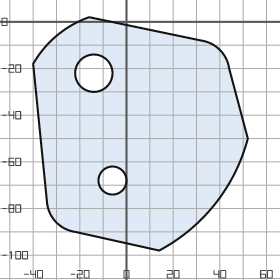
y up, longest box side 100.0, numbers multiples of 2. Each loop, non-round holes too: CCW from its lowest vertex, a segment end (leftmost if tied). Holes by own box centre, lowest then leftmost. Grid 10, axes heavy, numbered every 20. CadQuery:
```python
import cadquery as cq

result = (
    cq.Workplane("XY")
    .moveTo(14.0, -98.0)
    .threePointArc((38.0, -78.0), (52.0, -50.0))
    .lineTo(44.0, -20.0)
    .threePointArc((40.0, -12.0), (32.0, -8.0))
    .lineTo(-16.0, 2.0)
    .threePointArc((-30.0, -6.0), (-40.0, -18.0))
    .lineTo(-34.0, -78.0)
    .threePointArc((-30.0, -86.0), (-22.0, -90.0))
    .close()
    .moveTo(-6.0, -68.0)
    .circle(6.0)
    .moveTo(-14.0, -22.0)
    .circle(8.0)
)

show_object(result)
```